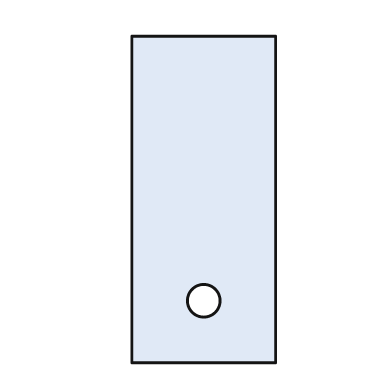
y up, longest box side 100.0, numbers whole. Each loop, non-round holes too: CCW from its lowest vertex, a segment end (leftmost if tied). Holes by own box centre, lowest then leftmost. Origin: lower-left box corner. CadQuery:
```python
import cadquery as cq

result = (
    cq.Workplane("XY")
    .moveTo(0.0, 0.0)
    .lineTo(44.0, 0.0)
    .lineTo(44.0, 100.0)
    .lineTo(0.0, 100.0)
    .close()
    .moveTo(22.0, 19.0)
    .circle(5.0)
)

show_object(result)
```